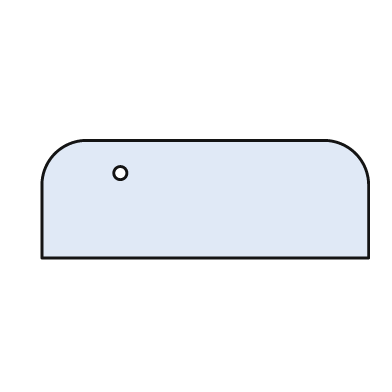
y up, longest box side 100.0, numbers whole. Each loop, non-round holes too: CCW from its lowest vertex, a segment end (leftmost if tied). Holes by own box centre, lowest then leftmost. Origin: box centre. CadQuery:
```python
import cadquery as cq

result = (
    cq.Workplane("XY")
    .moveTo(-50.0, -18.0)
    .lineTo(50.0, -18.0)
    .lineTo(50.0, 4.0)
    .threePointArc((46.0, 14.0), (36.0, 18.0))
    .lineTo(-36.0, 18.0)
    .threePointArc((-46.0, 14.0), (-50.0, 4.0))
    .close()
    .moveTo(-26.0, 8.0)
    .circle(2.0)
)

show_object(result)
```